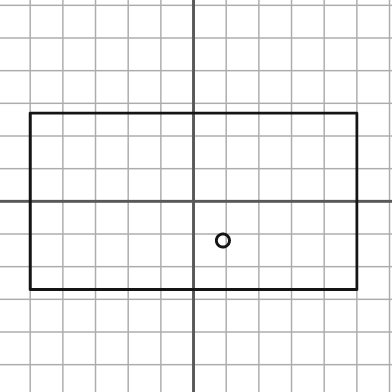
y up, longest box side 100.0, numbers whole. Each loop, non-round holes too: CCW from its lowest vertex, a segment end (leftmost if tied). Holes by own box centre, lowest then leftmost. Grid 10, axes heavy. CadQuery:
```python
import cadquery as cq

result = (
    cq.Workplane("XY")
    .moveTo(-50.0, -27.0)
    .lineTo(50.0, -27.0)
    .lineTo(50.0, 27.0)
    .lineTo(-50.0, 27.0)
    .close()
    .moveTo(9.0, -12.0)
    .circle(2.0)
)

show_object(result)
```